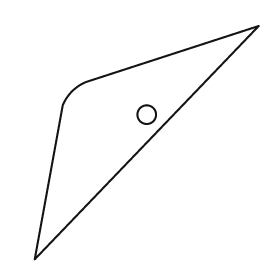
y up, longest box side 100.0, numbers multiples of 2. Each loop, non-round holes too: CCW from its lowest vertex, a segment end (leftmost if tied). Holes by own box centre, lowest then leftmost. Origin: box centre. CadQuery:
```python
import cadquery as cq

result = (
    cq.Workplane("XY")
    .moveTo(-48.0, -50.0)
    .lineTo(48.0, 50.0)
    .lineTo(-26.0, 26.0)
    .threePointArc((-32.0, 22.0), (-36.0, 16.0))
    .close()
    .moveTo(0.0, 12.0)
    .circle(4.0)
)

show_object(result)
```